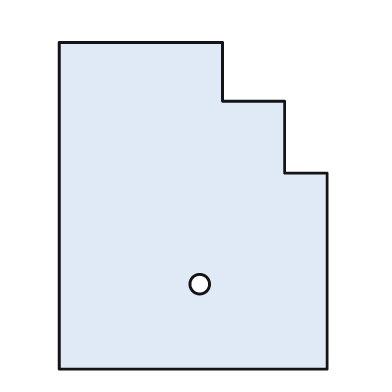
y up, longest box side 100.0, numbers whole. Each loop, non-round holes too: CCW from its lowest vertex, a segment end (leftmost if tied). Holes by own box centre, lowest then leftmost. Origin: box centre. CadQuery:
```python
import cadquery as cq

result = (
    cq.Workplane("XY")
    .moveTo(-41.0, -50.0)
    .lineTo(41.0, -50.0)
    .lineTo(41.0, 10.0)
    .lineTo(28.0, 10.0)
    .lineTo(28.0, 32.0)
    .lineTo(9.0, 32.0)
    .lineTo(9.0, 50.0)
    .lineTo(-41.0, 50.0)
    .close()
    .moveTo(2.0, -24.0)
    .circle(3.0)
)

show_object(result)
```